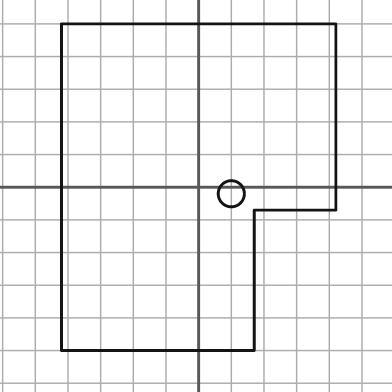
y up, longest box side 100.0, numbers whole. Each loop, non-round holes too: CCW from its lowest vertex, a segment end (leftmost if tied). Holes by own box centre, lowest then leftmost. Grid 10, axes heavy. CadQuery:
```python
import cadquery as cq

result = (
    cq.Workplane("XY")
    .moveTo(-42.0, -50.0)
    .lineTo(17.0, -50.0)
    .lineTo(17.0, -7.0)
    .lineTo(42.0, -7.0)
    .lineTo(42.0, 50.0)
    .lineTo(-42.0, 50.0)
    .close()
    .moveTo(10.0, -2.0)
    .circle(4.0)
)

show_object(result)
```